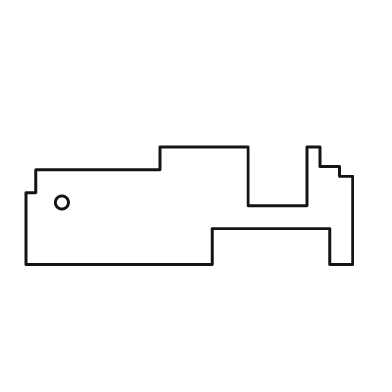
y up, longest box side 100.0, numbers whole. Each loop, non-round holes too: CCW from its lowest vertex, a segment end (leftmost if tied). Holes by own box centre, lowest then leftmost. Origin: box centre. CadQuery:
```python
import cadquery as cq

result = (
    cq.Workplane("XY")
    .moveTo(-50.0, -18.0)
    .lineTo(7.0, -18.0)
    .lineTo(7.0, -7.0)
    .lineTo(43.0, -7.0)
    .lineTo(43.0, -18.0)
    .lineTo(50.0, -18.0)
    .lineTo(50.0, 9.0)
    .lineTo(46.0, 9.0)
    .lineTo(46.0, 12.0)
    .lineTo(40.0, 12.0)
    .lineTo(40.0, 18.0)
    .lineTo(36.0, 18.0)
    .lineTo(36.0, 0.0)
    .lineTo(18.0, 0.0)
    .lineTo(18.0, 18.0)
    .lineTo(-9.0, 18.0)
    .lineTo(-9.0, 11.0)
    .lineTo(-47.0, 11.0)
    .lineTo(-47.0, 4.0)
    .lineTo(-50.0, 4.0)
    .close()
    .moveTo(-39.0, 1.0)
    .circle(2.0)
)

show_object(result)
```